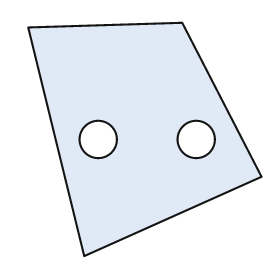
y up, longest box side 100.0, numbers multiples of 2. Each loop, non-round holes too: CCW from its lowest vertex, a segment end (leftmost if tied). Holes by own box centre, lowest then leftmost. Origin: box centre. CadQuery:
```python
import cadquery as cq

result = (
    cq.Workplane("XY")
    .moveTo(-26.0, -50.0)
    .lineTo(50.0, -16.0)
    .lineTo(16.0, 50.0)
    .lineTo(-50.0, 48.0)
    .close()
    .moveTo(-20.0, 0.0)
    .circle(8.0)
    .moveTo(22.0, 0.0)
    .circle(8.0)
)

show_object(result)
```